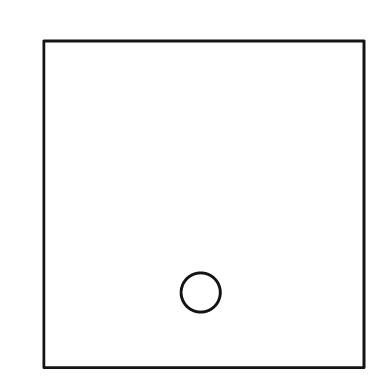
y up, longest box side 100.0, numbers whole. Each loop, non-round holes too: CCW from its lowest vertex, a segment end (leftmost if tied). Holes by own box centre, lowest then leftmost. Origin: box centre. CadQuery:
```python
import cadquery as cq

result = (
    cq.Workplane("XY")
    .moveTo(-49.0, -50.0)
    .lineTo(49.0, -50.0)
    .lineTo(49.0, 50.0)
    .lineTo(-49.0, 50.0)
    .close()
    .moveTo(-1.0, -27.0)
    .circle(6.0)
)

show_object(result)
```